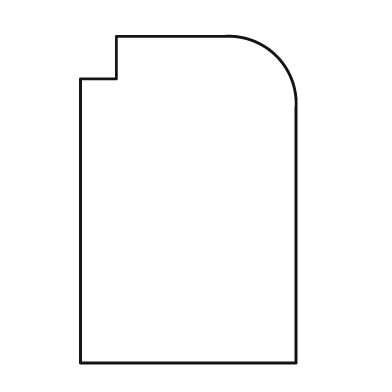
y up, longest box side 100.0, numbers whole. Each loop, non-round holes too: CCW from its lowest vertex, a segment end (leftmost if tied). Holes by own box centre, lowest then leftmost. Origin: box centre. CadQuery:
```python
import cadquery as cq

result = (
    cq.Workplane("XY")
    .moveTo(-33.0, -50.0)
    .lineTo(33.0, -50.0)
    .lineTo(33.0, 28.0)
    .threePointArc((27.0, 44.0), (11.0, 50.0))
    .lineTo(-22.0, 50.0)
    .lineTo(-22.0, 37.0)
    .lineTo(-33.0, 37.0)
    .close()
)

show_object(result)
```